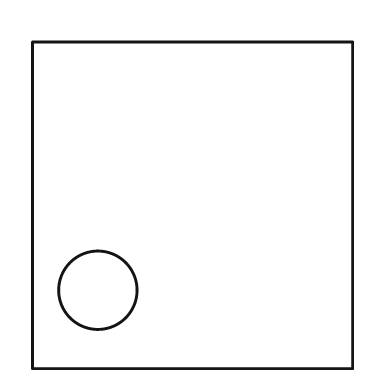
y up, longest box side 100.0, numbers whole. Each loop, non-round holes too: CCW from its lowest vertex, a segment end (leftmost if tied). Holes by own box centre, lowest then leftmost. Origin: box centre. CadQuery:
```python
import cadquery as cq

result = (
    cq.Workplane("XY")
    .moveTo(-49.0, -50.0)
    .lineTo(49.0, -50.0)
    .lineTo(49.0, 50.0)
    .lineTo(-49.0, 50.0)
    .close()
    .moveTo(-29.0, -26.0)
    .circle(12.0)
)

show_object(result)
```